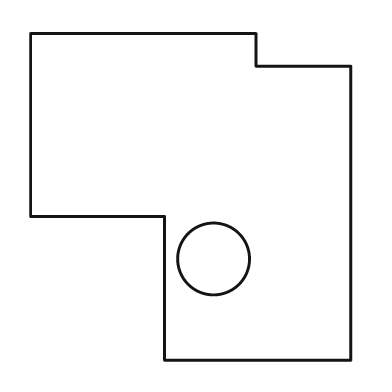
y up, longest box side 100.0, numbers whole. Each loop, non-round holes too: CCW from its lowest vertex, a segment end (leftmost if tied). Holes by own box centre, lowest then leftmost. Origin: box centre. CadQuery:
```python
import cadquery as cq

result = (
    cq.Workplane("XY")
    .moveTo(-8.0, -50.0)
    .lineTo(49.0, -50.0)
    .lineTo(49.0, 40.0)
    .lineTo(20.0, 40.0)
    .lineTo(20.0, 50.0)
    .lineTo(-49.0, 50.0)
    .lineTo(-49.0, -6.0)
    .lineTo(-8.0, -6.0)
    .close()
    .moveTo(7.0, -19.0)
    .circle(11.0)
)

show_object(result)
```